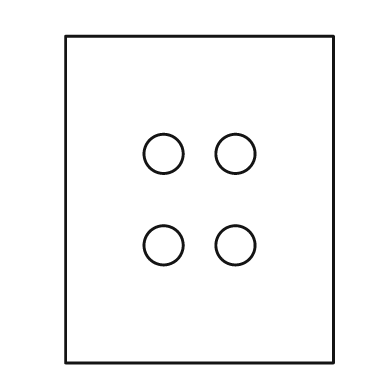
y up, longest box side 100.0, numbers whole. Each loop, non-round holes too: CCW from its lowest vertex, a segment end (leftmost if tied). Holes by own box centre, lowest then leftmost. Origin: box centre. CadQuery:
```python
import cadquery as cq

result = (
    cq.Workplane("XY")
    .moveTo(-41.0, -50.0)
    .lineTo(41.0, -50.0)
    .lineTo(41.0, 50.0)
    .lineTo(-41.0, 50.0)
    .close()
    .moveTo(-11.0, -14.0)
    .circle(6.0)
    .moveTo(11.0, -14.0)
    .circle(6.0)
    .moveTo(-11.0, 14.0)
    .circle(6.0)
    .moveTo(11.0, 14.0)
    .circle(6.0)
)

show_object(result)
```